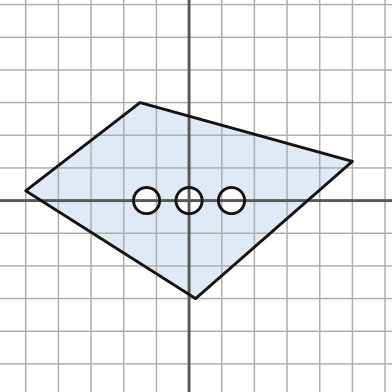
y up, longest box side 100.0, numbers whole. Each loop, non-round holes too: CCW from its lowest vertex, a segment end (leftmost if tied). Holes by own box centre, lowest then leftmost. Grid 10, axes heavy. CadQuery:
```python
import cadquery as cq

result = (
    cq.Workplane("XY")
    .moveTo(2.0, -30.0)
    .lineTo(50.0, 12.0)
    .lineTo(-15.0, 30.0)
    .lineTo(-50.0, 3.0)
    .close()
    .moveTo(-13.0, 0.0)
    .circle(4.0)
    .moveTo(0.0, 0.0)
    .circle(4.0)
    .moveTo(13.0, 0.0)
    .circle(4.0)
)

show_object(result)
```